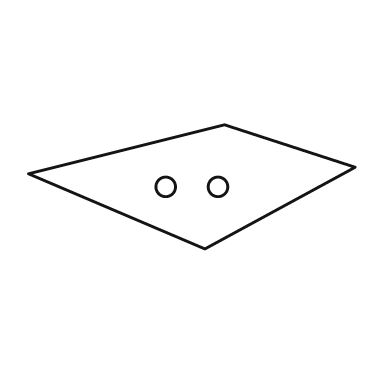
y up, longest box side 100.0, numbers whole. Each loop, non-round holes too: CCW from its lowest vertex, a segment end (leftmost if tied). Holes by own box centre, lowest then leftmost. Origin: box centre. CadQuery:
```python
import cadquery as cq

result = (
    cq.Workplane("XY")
    .moveTo(4.0, -19.0)
    .lineTo(50.0, 6.0)
    .lineTo(10.0, 19.0)
    .lineTo(-50.0, 4.0)
    .close()
    .moveTo(-8.0, 0.0)
    .circle(3.0)
    .moveTo(8.0, 0.0)
    .circle(3.0)
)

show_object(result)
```